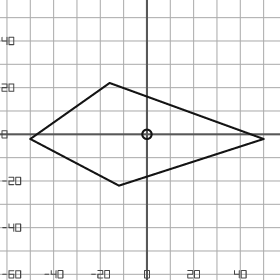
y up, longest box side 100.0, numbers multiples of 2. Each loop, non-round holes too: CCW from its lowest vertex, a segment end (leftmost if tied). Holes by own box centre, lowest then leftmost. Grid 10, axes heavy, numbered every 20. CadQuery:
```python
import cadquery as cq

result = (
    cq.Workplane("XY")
    .moveTo(-12.0, -22.0)
    .lineTo(50.0, -2.0)
    .lineTo(-16.0, 22.0)
    .lineTo(-50.0, -2.0)
    .close()
    .moveTo(0.0, 0.0)
    .circle(2.0)
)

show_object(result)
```